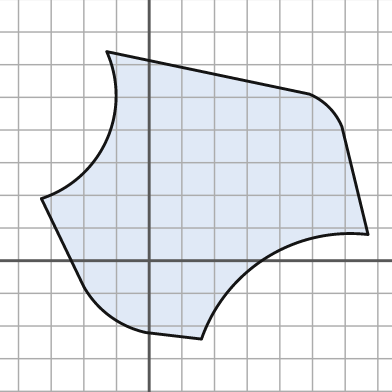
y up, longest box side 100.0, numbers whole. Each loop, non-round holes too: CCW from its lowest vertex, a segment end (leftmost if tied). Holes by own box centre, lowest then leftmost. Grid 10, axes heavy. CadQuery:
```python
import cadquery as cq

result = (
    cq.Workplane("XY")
    .moveTo(16.0, -24.0)
    .threePointArc((36.0, 1.0), (67.0, 8.0))
    .lineTo(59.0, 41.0)
    .threePointArc((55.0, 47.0), (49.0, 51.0))
    .lineTo(-13.0, 64.0)
    .threePointArc((-13.0, 37.0), (-33.0, 19.0))
    .lineTo(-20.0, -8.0)
    .threePointArc((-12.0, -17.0), (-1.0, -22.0))
    .close()
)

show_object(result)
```